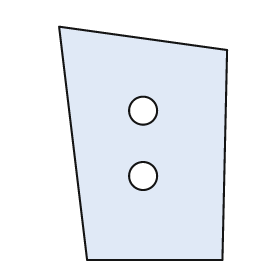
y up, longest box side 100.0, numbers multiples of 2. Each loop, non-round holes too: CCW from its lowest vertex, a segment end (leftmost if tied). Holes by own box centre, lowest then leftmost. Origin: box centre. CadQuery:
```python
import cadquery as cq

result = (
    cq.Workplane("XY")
    .moveTo(-24.0, -50.0)
    .lineTo(34.0, -50.0)
    .lineTo(36.0, 40.0)
    .lineTo(-36.0, 50.0)
    .close()
    .moveTo(0.0, -14.0)
    .circle(6.0)
    .moveTo(0.0, 14.0)
    .circle(6.0)
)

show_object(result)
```